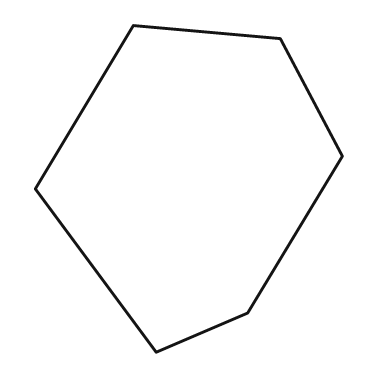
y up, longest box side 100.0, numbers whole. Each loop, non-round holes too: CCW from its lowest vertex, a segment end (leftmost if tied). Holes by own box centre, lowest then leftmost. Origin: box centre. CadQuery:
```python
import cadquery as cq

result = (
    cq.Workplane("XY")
    .moveTo(-10.0, -50.0)
    .lineTo(18.0, -38.0)
    .lineTo(47.0, 10.0)
    .lineTo(28.0, 46.0)
    .lineTo(-17.0, 50.0)
    .lineTo(-47.0, 0.0)
    .close()
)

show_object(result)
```